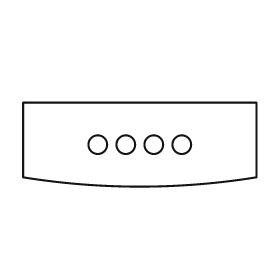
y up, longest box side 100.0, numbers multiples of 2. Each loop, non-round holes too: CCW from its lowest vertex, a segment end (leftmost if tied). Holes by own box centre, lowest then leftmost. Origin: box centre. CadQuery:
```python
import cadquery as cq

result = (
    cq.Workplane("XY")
    .moveTo(-50.0, -14.0)
    .threePointArc((0.0, -18.0), (50.0, -14.0))
    .lineTo(50.0, 18.0)
    .lineTo(-50.0, 18.0)
    .close()
    .moveTo(-18.0, 0.0)
    .circle(4.0)
    .moveTo(-6.0, 0.0)
    .circle(4.0)
    .moveTo(6.0, 0.0)
    .circle(4.0)
    .moveTo(18.0, 0.0)
    .circle(4.0)
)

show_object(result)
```